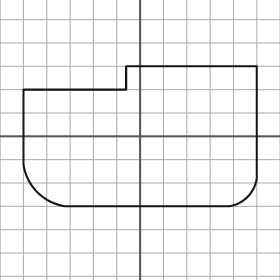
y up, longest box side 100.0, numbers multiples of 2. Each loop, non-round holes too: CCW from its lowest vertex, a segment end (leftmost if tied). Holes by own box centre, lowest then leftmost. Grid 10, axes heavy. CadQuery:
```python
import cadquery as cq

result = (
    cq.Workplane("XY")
    .moveTo(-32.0, -30.0)
    .lineTo(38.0, -30.0)
    .threePointArc((46.0, -26.0), (50.0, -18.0))
    .lineTo(50.0, 30.0)
    .lineTo(-6.0, 30.0)
    .lineTo(-6.0, 20.0)
    .lineTo(-50.0, 20.0)
    .lineTo(-50.0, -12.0)
    .threePointArc((-44.0, -24.0), (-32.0, -30.0))
    .close()
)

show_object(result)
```